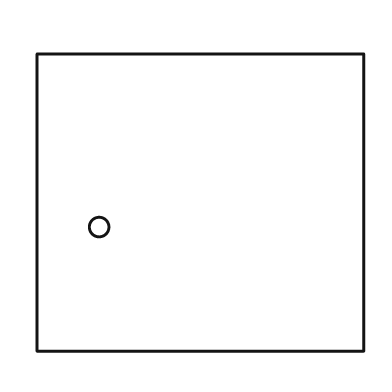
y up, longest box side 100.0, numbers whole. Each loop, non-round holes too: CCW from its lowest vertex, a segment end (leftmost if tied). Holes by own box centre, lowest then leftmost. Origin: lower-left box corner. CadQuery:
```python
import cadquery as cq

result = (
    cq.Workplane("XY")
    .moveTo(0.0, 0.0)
    .lineTo(100.0, 0.0)
    .lineTo(100.0, 91.0)
    .lineTo(0.0, 91.0)
    .close()
    .moveTo(19.0, 38.0)
    .circle(3.0)
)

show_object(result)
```